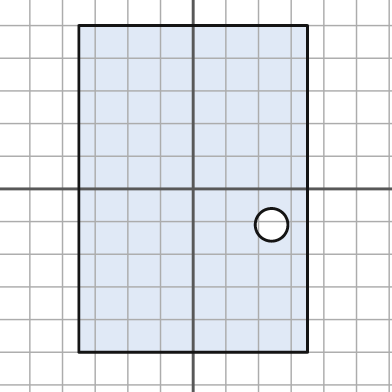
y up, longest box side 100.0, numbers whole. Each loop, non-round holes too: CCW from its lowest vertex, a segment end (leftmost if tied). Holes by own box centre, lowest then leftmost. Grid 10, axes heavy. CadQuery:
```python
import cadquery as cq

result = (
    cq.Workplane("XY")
    .moveTo(-35.0, -50.0)
    .lineTo(35.0, -50.0)
    .lineTo(35.0, 50.0)
    .lineTo(-35.0, 50.0)
    .close()
    .moveTo(24.0, -11.0)
    .circle(5.0)
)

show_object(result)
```